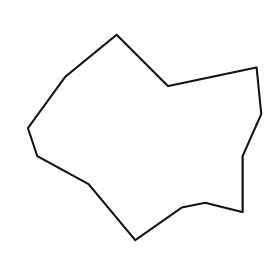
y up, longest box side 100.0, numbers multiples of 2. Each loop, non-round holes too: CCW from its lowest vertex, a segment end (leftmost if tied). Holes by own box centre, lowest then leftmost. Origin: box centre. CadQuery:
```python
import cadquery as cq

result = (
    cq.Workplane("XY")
    .moveTo(-4.0, -44.0)
    .lineTo(16.0, -30.0)
    .lineTo(26.0, -28.0)
    .lineTo(42.0, -32.0)
    .lineTo(42.0, -8.0)
    .lineTo(50.0, 10.0)
    .lineTo(48.0, 30.0)
    .lineTo(10.0, 22.0)
    .lineTo(-12.0, 44.0)
    .lineTo(-34.0, 26.0)
    .lineTo(-50.0, 4.0)
    .lineTo(-46.0, -8.0)
    .lineTo(-24.0, -20.0)
    .close()
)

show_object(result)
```